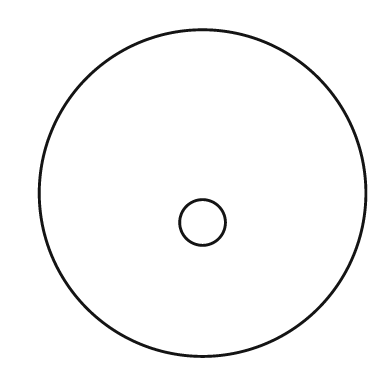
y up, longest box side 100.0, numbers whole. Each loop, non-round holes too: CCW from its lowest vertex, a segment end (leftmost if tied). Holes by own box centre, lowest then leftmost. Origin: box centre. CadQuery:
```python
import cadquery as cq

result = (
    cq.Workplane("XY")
    .moveTo(0.0, 0.0)
    .circle(50.0)
    .moveTo(0.0, -9.0)
    .circle(7.0)
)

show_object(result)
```